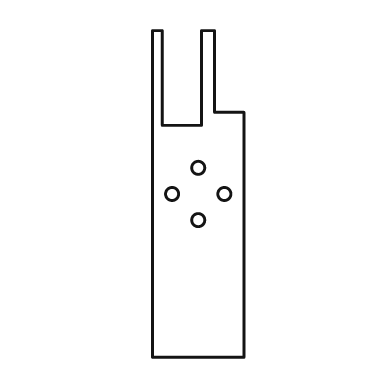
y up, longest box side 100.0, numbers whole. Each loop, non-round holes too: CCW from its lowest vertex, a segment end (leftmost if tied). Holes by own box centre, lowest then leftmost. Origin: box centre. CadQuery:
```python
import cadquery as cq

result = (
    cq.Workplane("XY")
    .moveTo(-14.0, -50.0)
    .lineTo(14.0, -50.0)
    .lineTo(14.0, 25.0)
    .lineTo(5.0, 25.0)
    .lineTo(5.0, 50.0)
    .lineTo(1.0, 50.0)
    .lineTo(1.0, 21.0)
    .lineTo(-11.0, 21.0)
    .lineTo(-11.0, 50.0)
    .lineTo(-14.0, 50.0)
    .close()
    .moveTo(0.0, -8.0)
    .circle(2.0)
    .moveTo(-8.0, 0.0)
    .circle(2.0)
    .moveTo(8.0, 0.0)
    .circle(2.0)
    .moveTo(0.0, 8.0)
    .circle(2.0)
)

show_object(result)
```